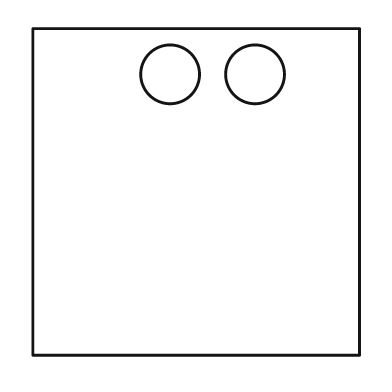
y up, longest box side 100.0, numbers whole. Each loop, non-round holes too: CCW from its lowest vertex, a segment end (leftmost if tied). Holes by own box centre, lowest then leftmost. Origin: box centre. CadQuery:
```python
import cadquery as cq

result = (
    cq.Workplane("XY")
    .moveTo(-50.0, -50.0)
    .lineTo(50.0, -50.0)
    .lineTo(50.0, 50.0)
    .lineTo(-50.0, 50.0)
    .close()
    .moveTo(-8.0, 36.0)
    .circle(9.0)
    .moveTo(18.0, 36.0)
    .circle(9.0)
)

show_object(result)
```